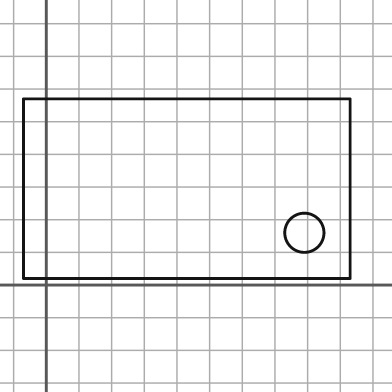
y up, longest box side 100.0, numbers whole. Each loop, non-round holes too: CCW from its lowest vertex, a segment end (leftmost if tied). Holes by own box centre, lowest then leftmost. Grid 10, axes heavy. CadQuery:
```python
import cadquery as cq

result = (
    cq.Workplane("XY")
    .moveTo(-7.0, 2.0)
    .lineTo(93.0, 2.0)
    .lineTo(93.0, 57.0)
    .lineTo(-7.0, 57.0)
    .close()
    .moveTo(79.0, 16.0)
    .circle(6.0)
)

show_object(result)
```